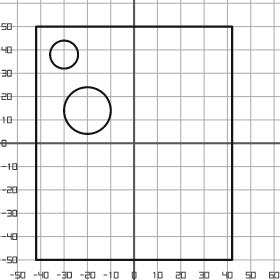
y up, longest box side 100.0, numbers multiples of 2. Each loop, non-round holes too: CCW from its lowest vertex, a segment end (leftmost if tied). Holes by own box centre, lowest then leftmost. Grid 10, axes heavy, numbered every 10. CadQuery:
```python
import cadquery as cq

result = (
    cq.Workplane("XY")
    .moveTo(-42.0, -50.0)
    .lineTo(42.0, -50.0)
    .lineTo(42.0, 50.0)
    .lineTo(-42.0, 50.0)
    .close()
    .moveTo(-20.0, 14.0)
    .circle(10.0)
    .moveTo(-30.0, 38.0)
    .circle(6.0)
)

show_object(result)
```